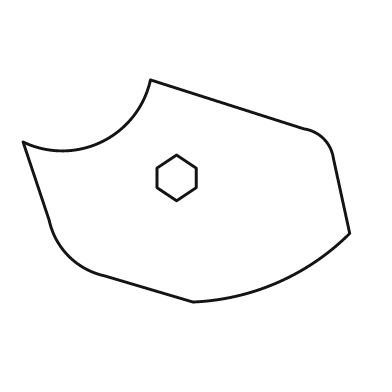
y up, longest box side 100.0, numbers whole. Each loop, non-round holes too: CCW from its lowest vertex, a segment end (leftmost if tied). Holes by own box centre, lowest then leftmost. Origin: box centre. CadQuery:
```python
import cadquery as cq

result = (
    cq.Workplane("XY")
    .moveTo(2.0, -34.0)
    .threePointArc((28.0, -28.0), (50.0, -13.0))
    .lineTo(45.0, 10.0)
    .threePointArc((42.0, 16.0), (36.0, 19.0))
    .lineTo(-11.0, 34.0)
    .threePointArc((-26.0, 15.0), (-50.0, 15.0))
    .lineTo(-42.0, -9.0)
    .threePointArc((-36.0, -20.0), (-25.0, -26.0))
    .close()
    .moveTo(-3.0, -3.0)
    .lineTo(3.0, 1.0)
    .lineTo(3.0, 7.0)
    .lineTo(-3.0, 11.0)
    .lineTo(-9.0, 7.0)
    .lineTo(-9.0, 1.0)
    .close()
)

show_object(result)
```